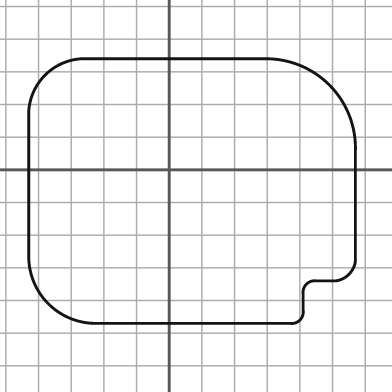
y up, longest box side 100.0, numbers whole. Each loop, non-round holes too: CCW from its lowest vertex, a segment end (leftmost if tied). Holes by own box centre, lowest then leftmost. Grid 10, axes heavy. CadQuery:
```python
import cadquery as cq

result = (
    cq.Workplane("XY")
    .moveTo(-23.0, -47.0)
    .lineTo(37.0, -47.0)
    .threePointArc((40.0, -46.0), (41.0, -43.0))
    .lineTo(41.0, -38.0)
    .threePointArc((42.0, -35.0), (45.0, -34.0))
    .lineTo(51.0, -34.0)
    .threePointArc((55.0, -32.0), (57.0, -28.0))
    .lineTo(57.0, 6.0)
    .threePointArc((49.0, 26.0), (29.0, 34.0))
    .lineTo(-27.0, 34.0)
    .threePointArc((-38.0, 29.0), (-43.0, 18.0))
    .lineTo(-43.0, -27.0)
    .threePointArc((-37.0, -41.0), (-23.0, -47.0))
    .close()
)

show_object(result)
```